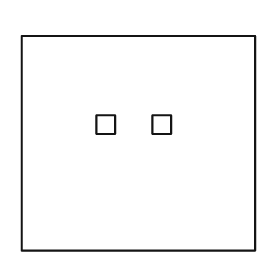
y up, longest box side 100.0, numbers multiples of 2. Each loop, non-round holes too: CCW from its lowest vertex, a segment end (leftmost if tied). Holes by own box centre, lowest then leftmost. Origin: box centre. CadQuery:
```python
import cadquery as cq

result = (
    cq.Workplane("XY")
    .moveTo(-50.0, -46.0)
    .lineTo(50.0, -46.0)
    .lineTo(50.0, 46.0)
    .lineTo(-50.0, 46.0)
    .close()
    .moveTo(-18.0, 4.0)
    .lineTo(-10.0, 4.0)
    .lineTo(-10.0, 12.0)
    .lineTo(-18.0, 12.0)
    .close()
    .moveTo(6.0, 4.0)
    .lineTo(14.0, 4.0)
    .lineTo(14.0, 12.0)
    .lineTo(6.0, 12.0)
    .close()
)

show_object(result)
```